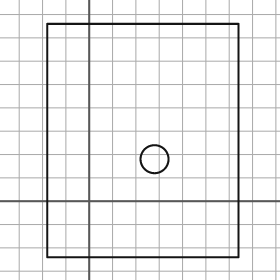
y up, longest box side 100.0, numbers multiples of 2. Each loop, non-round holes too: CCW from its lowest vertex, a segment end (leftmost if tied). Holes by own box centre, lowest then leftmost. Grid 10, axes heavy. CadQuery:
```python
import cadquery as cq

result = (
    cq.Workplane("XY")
    .moveTo(-18.0, -24.0)
    .lineTo(64.0, -24.0)
    .lineTo(64.0, 76.0)
    .lineTo(-18.0, 76.0)
    .close()
    .moveTo(28.0, 18.0)
    .circle(6.0)
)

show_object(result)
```